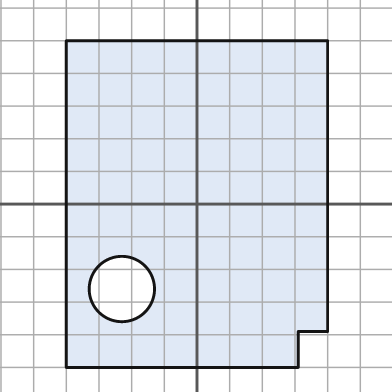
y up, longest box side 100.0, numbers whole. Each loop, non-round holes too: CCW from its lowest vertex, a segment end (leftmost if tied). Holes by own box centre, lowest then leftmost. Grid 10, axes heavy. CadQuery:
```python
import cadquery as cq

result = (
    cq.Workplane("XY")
    .moveTo(-40.0, -50.0)
    .lineTo(31.0, -50.0)
    .lineTo(31.0, -39.0)
    .lineTo(40.0, -39.0)
    .lineTo(40.0, 50.0)
    .lineTo(-40.0, 50.0)
    .close()
    .moveTo(-23.0, -26.0)
    .circle(10.0)
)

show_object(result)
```